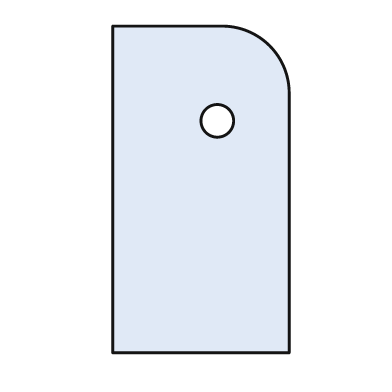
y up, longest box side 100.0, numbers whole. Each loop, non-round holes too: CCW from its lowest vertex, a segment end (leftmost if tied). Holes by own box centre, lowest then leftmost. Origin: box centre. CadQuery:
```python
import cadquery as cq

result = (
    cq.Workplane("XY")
    .moveTo(-27.0, -50.0)
    .lineTo(27.0, -50.0)
    .lineTo(27.0, 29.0)
    .threePointArc((21.0, 44.0), (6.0, 50.0))
    .lineTo(-27.0, 50.0)
    .close()
    .moveTo(5.0, 21.0)
    .circle(5.0)
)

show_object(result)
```